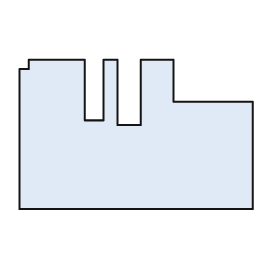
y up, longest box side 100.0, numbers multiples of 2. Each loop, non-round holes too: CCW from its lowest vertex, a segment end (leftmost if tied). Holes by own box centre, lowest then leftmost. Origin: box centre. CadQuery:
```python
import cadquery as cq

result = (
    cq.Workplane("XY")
    .moveTo(-50.0, -32.0)
    .lineTo(50.0, -32.0)
    .lineTo(50.0, 14.0)
    .lineTo(16.0, 14.0)
    .lineTo(16.0, 32.0)
    .lineTo(2.0, 32.0)
    .lineTo(2.0, 4.0)
    .lineTo(-8.0, 4.0)
    .lineTo(-8.0, 32.0)
    .lineTo(-14.0, 32.0)
    .lineTo(-14.0, 6.0)
    .lineTo(-22.0, 6.0)
    .lineTo(-22.0, 32.0)
    .lineTo(-46.0, 32.0)
    .lineTo(-46.0, 28.0)
    .lineTo(-50.0, 28.0)
    .close()
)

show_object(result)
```